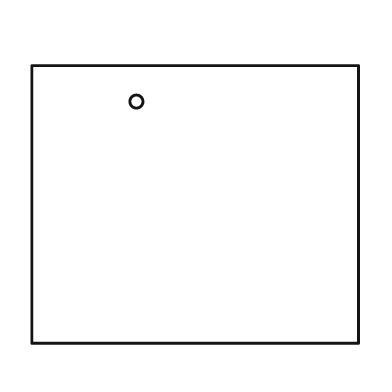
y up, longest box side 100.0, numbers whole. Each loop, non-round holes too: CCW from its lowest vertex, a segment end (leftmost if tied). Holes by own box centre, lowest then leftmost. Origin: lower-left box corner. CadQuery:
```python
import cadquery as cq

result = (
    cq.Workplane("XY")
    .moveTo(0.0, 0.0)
    .lineTo(100.0, 0.0)
    .lineTo(100.0, 85.0)
    .lineTo(0.0, 85.0)
    .close()
    .moveTo(32.0, 74.0)
    .circle(2.0)
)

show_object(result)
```